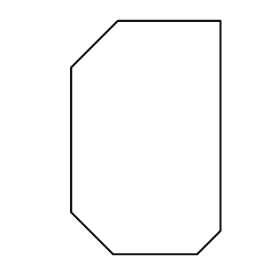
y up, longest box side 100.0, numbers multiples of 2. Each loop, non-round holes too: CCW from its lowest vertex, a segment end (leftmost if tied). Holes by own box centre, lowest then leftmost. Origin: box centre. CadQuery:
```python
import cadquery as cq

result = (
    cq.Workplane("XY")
    .moveTo(-14.0, -50.0)
    .lineTo(22.0, -50.0)
    .lineTo(32.0, -40.0)
    .lineTo(32.0, 50.0)
    .lineTo(-12.0, 50.0)
    .lineTo(-32.0, 30.0)
    .lineTo(-32.0, -32.0)
    .close()
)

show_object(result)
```